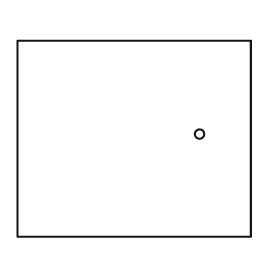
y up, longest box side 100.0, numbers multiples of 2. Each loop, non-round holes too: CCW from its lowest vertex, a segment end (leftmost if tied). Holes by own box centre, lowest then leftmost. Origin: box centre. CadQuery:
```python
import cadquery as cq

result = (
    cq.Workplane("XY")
    .moveTo(-50.0, -42.0)
    .lineTo(50.0, -42.0)
    .lineTo(50.0, 42.0)
    .lineTo(-50.0, 42.0)
    .close()
    .moveTo(28.0, 2.0)
    .circle(2.0)
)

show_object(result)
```